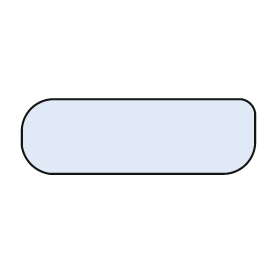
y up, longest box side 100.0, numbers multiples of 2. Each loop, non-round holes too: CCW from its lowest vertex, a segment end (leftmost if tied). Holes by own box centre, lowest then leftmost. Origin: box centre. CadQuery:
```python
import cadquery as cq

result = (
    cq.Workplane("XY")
    .moveTo(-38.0, -16.0)
    .lineTo(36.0, -16.0)
    .threePointArc((46.0, -12.0), (50.0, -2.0))
    .lineTo(50.0, 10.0)
    .threePointArc((48.0, 14.0), (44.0, 16.0))
    .lineTo(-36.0, 16.0)
    .threePointArc((-46.0, 12.0), (-50.0, 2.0))
    .lineTo(-50.0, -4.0)
    .threePointArc((-46.0, -12.0), (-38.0, -16.0))
    .close()
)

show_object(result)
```